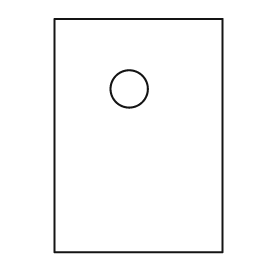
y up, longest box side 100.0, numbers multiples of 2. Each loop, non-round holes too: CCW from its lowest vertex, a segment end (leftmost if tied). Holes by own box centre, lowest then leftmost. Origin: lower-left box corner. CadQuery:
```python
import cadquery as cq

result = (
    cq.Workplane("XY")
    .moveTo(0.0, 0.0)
    .lineTo(72.0, 0.0)
    .lineTo(72.0, 100.0)
    .lineTo(0.0, 100.0)
    .close()
    .moveTo(32.0, 70.0)
    .circle(8.0)
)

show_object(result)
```